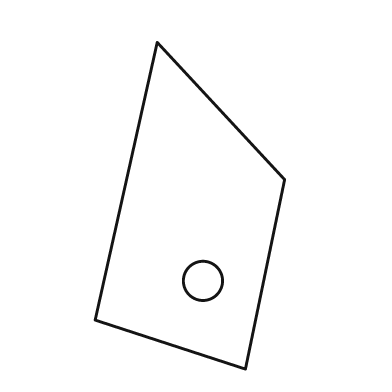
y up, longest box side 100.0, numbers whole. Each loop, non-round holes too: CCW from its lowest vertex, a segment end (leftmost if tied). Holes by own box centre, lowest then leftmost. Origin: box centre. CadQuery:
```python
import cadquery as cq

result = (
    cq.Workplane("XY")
    .moveTo(17.0, -50.0)
    .lineTo(29.0, 8.0)
    .lineTo(-10.0, 50.0)
    .lineTo(-29.0, -35.0)
    .close()
    .moveTo(4.0, -23.0)
    .circle(6.0)
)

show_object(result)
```